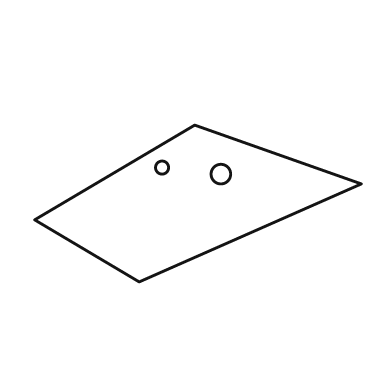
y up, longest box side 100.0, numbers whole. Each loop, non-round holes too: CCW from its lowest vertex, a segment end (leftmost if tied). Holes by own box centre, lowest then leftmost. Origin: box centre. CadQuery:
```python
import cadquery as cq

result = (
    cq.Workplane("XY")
    .moveTo(-18.0, -24.0)
    .lineTo(50.0, 6.0)
    .lineTo(-1.0, 24.0)
    .lineTo(-50.0, -5.0)
    .close()
    .moveTo(7.0, 9.0)
    .circle(3.0)
    .moveTo(-11.0, 11.0)
    .circle(2.0)
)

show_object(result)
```